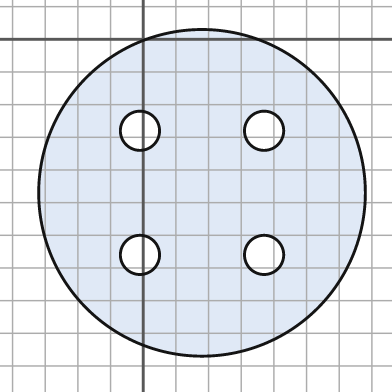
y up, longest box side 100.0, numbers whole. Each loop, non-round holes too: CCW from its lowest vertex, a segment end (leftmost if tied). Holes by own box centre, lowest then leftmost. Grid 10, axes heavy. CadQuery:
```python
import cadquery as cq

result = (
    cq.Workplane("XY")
    .moveTo(18.0, -47.0)
    .circle(50.0)
    .moveTo(-1.0, -66.0)
    .circle(6.0)
    .moveTo(37.0, -66.0)
    .circle(6.0)
    .moveTo(-1.0, -28.0)
    .circle(6.0)
    .moveTo(37.0, -28.0)
    .circle(6.0)
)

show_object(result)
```